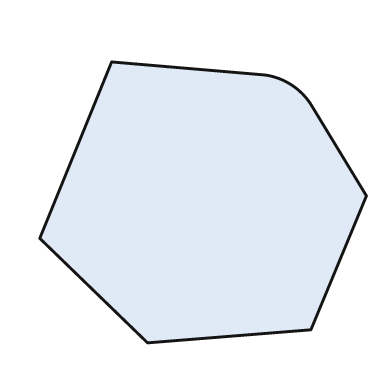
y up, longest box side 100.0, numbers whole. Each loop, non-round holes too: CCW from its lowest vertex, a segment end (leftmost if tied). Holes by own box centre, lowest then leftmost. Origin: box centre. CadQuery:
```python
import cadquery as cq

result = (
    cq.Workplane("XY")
    .moveTo(-17.0, -43.0)
    .lineTo(33.0, -39.0)
    .lineTo(50.0, 2.0)
    .lineTo(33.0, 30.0)
    .threePointArc((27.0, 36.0), (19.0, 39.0))
    .lineTo(-28.0, 43.0)
    .lineTo(-50.0, -11.0)
    .close()
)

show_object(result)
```